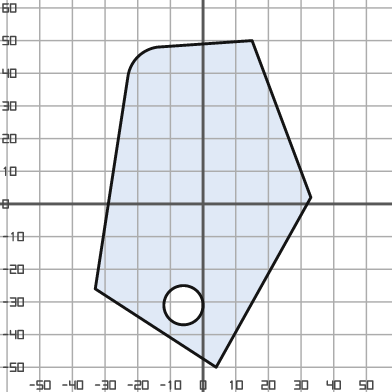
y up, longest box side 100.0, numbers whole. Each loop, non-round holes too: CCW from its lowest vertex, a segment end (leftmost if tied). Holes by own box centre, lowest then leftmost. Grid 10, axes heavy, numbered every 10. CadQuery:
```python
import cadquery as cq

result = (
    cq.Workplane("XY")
    .moveTo(4.0, -50.0)
    .lineTo(33.0, 2.0)
    .lineTo(15.0, 50.0)
    .lineTo(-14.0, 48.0)
    .threePointArc((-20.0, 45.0), (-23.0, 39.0))
    .lineTo(-33.0, -26.0)
    .close()
    .moveTo(-6.0, -31.0)
    .circle(6.0)
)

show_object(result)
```